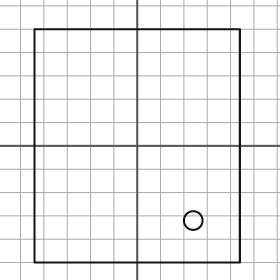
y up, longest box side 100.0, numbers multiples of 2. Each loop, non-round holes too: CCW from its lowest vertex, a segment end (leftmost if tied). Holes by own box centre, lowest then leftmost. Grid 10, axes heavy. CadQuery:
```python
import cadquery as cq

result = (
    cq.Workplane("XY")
    .moveTo(-44.0, -50.0)
    .lineTo(44.0, -50.0)
    .lineTo(44.0, 50.0)
    .lineTo(-44.0, 50.0)
    .close()
    .moveTo(24.0, -32.0)
    .circle(4.0)
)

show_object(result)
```